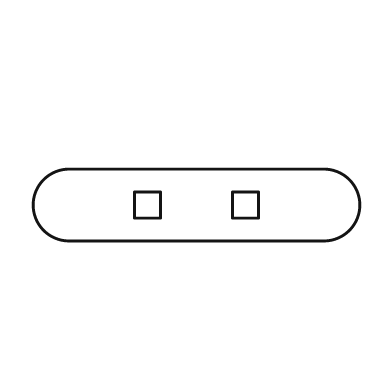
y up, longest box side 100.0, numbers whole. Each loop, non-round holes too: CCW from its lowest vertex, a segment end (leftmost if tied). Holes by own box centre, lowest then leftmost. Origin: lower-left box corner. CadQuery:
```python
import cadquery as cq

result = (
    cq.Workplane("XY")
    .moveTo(11.0, 0.0)
    .lineTo(89.0, 0.0)
    .threePointArc((100.0, 11.0), (89.0, 22.0))
    .lineTo(11.0, 22.0)
    .threePointArc((0.0, 11.0), (11.0, 0.0))
    .close()
    .moveTo(31.0, 7.0)
    .lineTo(39.0, 7.0)
    .lineTo(39.0, 15.0)
    .lineTo(31.0, 15.0)
    .close()
    .moveTo(61.0, 7.0)
    .lineTo(69.0, 7.0)
    .lineTo(69.0, 15.0)
    .lineTo(61.0, 15.0)
    .close()
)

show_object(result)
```